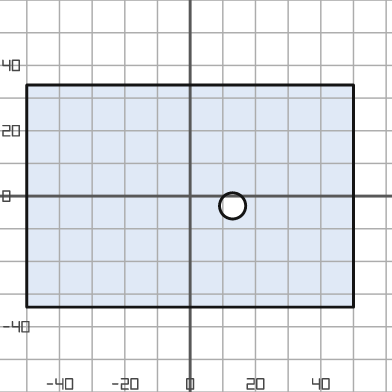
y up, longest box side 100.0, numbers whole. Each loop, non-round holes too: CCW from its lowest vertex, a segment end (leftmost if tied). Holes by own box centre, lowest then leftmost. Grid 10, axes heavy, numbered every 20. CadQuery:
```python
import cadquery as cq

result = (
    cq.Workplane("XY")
    .moveTo(-50.0, -34.0)
    .lineTo(50.0, -34.0)
    .lineTo(50.0, 34.0)
    .lineTo(-50.0, 34.0)
    .close()
    .moveTo(13.0, -3.0)
    .circle(4.0)
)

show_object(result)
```